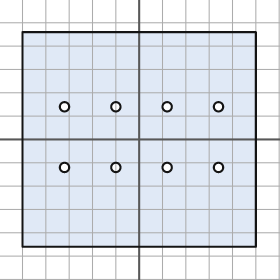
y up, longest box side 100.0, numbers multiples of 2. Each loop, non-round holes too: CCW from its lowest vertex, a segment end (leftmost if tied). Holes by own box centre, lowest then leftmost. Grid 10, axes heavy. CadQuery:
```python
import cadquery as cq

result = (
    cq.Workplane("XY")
    .moveTo(-50.0, -46.0)
    .lineTo(50.0, -46.0)
    .lineTo(50.0, 46.0)
    .lineTo(-50.0, 46.0)
    .close()
    .moveTo(-32.0, -12.0)
    .circle(2.0)
    .moveTo(-10.0, -12.0)
    .circle(2.0)
    .moveTo(12.0, -12.0)
    .circle(2.0)
    .moveTo(34.0, -12.0)
    .circle(2.0)
    .moveTo(-32.0, 14.0)
    .circle(2.0)
    .moveTo(-10.0, 14.0)
    .circle(2.0)
    .moveTo(12.0, 14.0)
    .circle(2.0)
    .moveTo(34.0, 14.0)
    .circle(2.0)
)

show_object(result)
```